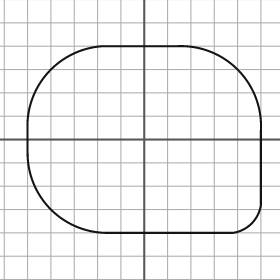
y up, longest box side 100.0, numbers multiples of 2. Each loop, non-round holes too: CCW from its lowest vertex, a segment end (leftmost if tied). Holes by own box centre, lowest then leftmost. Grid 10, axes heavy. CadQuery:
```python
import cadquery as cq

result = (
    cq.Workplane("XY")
    .moveTo(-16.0, -40.0)
    .lineTo(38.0, -40.0)
    .threePointArc((46.0, -36.0), (50.0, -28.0))
    .lineTo(50.0, 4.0)
    .threePointArc((40.0, 30.0), (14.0, 40.0))
    .lineTo(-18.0, 40.0)
    .threePointArc((-40.0, 30.0), (-50.0, 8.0))
    .lineTo(-50.0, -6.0)
    .threePointArc((-40.0, -30.0), (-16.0, -40.0))
    .close()
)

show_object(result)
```